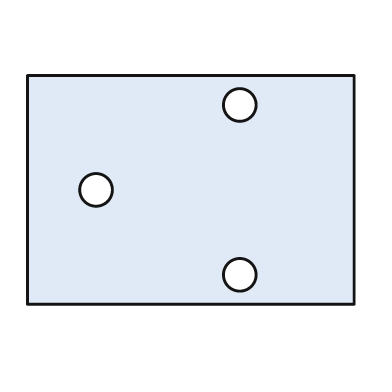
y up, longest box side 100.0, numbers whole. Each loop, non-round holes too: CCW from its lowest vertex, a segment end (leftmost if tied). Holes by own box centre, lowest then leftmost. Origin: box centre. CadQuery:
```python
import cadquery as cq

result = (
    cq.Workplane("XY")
    .moveTo(-50.0, -35.0)
    .lineTo(50.0, -35.0)
    .lineTo(50.0, 35.0)
    .lineTo(-50.0, 35.0)
    .close()
    .moveTo(15.0, -26.0)
    .circle(5.0)
    .moveTo(-29.0, 0.0)
    .circle(5.0)
    .moveTo(15.0, 26.0)
    .circle(5.0)
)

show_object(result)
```